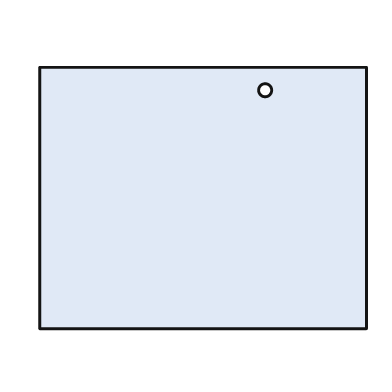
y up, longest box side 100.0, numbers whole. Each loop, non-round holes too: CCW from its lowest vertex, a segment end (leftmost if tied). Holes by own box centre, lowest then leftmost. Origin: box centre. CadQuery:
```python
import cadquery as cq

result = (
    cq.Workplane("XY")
    .moveTo(-50.0, -40.0)
    .lineTo(50.0, -40.0)
    .lineTo(50.0, 40.0)
    .lineTo(-50.0, 40.0)
    .close()
    .moveTo(19.0, 33.0)
    .circle(2.0)
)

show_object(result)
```